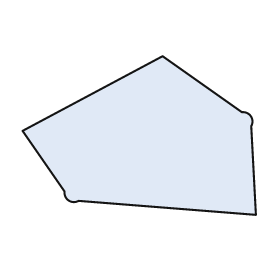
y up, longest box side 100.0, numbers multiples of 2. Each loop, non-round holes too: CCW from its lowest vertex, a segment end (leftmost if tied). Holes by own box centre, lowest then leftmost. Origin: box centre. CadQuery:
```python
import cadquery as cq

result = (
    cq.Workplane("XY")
    .moveTo(50.0, -34.0)
    .lineTo(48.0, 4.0)
    .threePointArc((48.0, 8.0), (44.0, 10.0))
    .lineTo(10.0, 34.0)
    .lineTo(-50.0, 2.0)
    .lineTo(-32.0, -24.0)
    .threePointArc((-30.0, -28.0), (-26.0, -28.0))
    .close()
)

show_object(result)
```